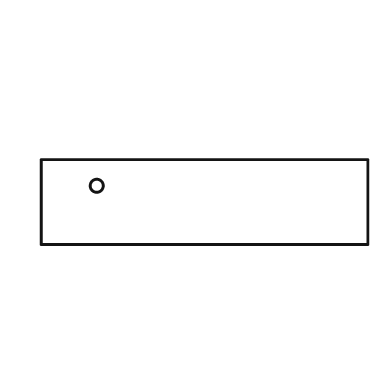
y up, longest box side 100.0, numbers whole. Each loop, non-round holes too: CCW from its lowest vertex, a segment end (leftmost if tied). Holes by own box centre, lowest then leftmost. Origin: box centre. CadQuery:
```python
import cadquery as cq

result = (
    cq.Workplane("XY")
    .moveTo(-50.0, -13.0)
    .lineTo(50.0, -13.0)
    .lineTo(50.0, 13.0)
    .lineTo(-50.0, 13.0)
    .close()
    .moveTo(-33.0, 5.0)
    .circle(2.0)
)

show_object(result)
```